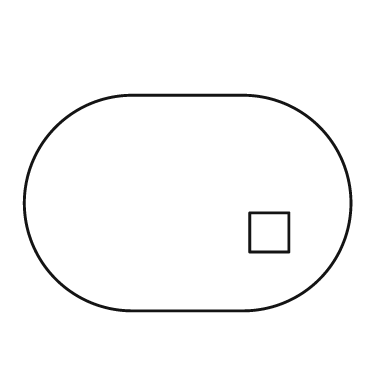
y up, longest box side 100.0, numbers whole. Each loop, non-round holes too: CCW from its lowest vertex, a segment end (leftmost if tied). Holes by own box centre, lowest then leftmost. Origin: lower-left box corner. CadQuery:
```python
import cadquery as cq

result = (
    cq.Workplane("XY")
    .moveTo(33.0, 0.0)
    .lineTo(67.0, 0.0)
    .threePointArc((100.0, 33.0), (67.0, 66.0))
    .lineTo(33.0, 66.0)
    .threePointArc((0.0, 33.0), (33.0, 0.0))
    .close()
    .moveTo(69.0, 18.0)
    .lineTo(81.0, 18.0)
    .lineTo(81.0, 30.0)
    .lineTo(69.0, 30.0)
    .close()
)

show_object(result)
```